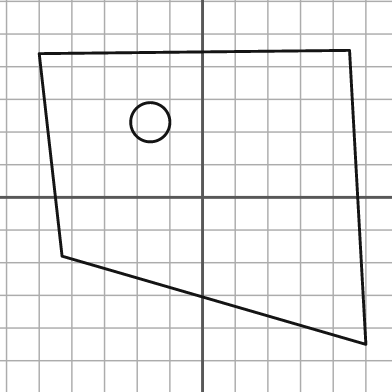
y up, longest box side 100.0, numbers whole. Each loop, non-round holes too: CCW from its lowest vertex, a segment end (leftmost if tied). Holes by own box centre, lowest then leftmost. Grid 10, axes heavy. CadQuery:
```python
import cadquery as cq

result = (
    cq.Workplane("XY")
    .moveTo(50.0, -45.0)
    .lineTo(45.0, 45.0)
    .lineTo(-50.0, 44.0)
    .lineTo(-43.0, -18.0)
    .close()
    .moveTo(-16.0, 23.0)
    .circle(6.0)
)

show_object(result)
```